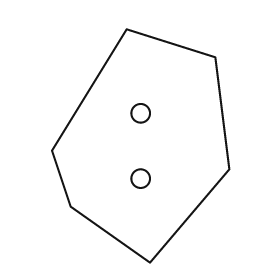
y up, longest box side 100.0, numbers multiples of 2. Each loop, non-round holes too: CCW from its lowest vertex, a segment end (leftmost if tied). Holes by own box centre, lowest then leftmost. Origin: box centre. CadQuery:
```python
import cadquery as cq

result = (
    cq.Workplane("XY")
    .moveTo(4.0, -50.0)
    .lineTo(38.0, -10.0)
    .lineTo(32.0, 38.0)
    .lineTo(-6.0, 50.0)
    .lineTo(-38.0, -2.0)
    .lineTo(-30.0, -26.0)
    .close()
    .moveTo(0.0, -14.0)
    .circle(4.0)
    .moveTo(0.0, 14.0)
    .circle(4.0)
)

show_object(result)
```